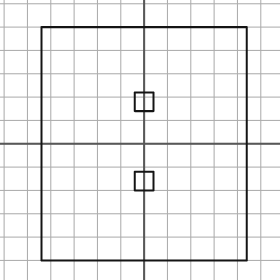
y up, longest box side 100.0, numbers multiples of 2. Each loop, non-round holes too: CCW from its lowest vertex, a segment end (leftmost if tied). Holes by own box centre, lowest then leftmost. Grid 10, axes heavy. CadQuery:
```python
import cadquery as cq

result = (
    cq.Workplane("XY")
    .moveTo(-44.0, -50.0)
    .lineTo(44.0, -50.0)
    .lineTo(44.0, 50.0)
    .lineTo(-44.0, 50.0)
    .close()
    .moveTo(-4.0, -20.0)
    .lineTo(4.0, -20.0)
    .lineTo(4.0, -12.0)
    .lineTo(-4.0, -12.0)
    .close()
    .moveTo(-4.0, 14.0)
    .lineTo(4.0, 14.0)
    .lineTo(4.0, 22.0)
    .lineTo(-4.0, 22.0)
    .close()
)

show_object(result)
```